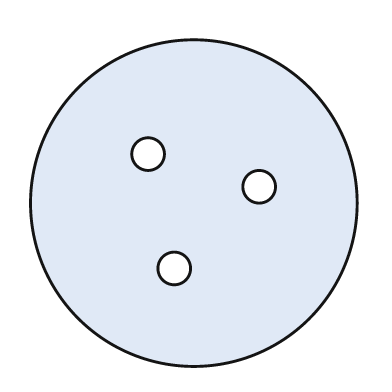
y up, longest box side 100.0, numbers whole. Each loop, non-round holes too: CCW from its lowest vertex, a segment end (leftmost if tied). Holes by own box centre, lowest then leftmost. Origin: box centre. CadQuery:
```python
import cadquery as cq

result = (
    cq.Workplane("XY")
    .moveTo(0.0, 0.0)
    .circle(50.0)
    .moveTo(-6.0, -20.0)
    .circle(5.0)
    .moveTo(20.0, 5.0)
    .circle(5.0)
    .moveTo(-14.0, 15.0)
    .circle(5.0)
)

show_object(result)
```